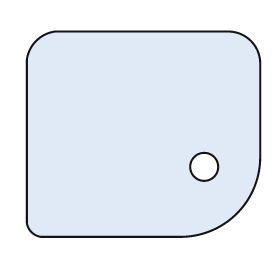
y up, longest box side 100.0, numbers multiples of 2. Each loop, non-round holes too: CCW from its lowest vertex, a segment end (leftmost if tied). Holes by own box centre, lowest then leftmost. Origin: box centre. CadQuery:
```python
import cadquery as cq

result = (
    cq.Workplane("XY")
    .moveTo(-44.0, -44.0)
    .lineTo(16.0, -44.0)
    .threePointArc((40.0, -34.0), (50.0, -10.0))
    .lineTo(50.0, 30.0)
    .threePointArc((46.0, 40.0), (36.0, 44.0))
    .lineTo(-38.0, 44.0)
    .threePointArc((-46.0, 40.0), (-50.0, 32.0))
    .lineTo(-50.0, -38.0)
    .threePointArc((-48.0, -42.0), (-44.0, -44.0))
    .close()
    .moveTo(26.0, -14.0)
    .circle(6.0)
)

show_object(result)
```